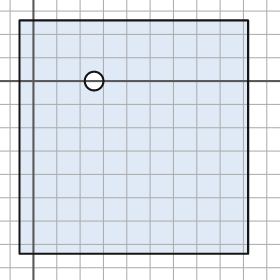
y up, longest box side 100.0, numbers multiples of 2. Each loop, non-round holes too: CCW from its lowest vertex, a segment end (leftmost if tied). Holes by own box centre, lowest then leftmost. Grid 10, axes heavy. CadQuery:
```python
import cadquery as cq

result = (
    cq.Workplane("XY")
    .moveTo(-6.0, -74.0)
    .lineTo(92.0, -74.0)
    .lineTo(92.0, 26.0)
    .lineTo(-6.0, 26.0)
    .close()
    .moveTo(26.0, 0.0)
    .circle(4.0)
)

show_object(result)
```